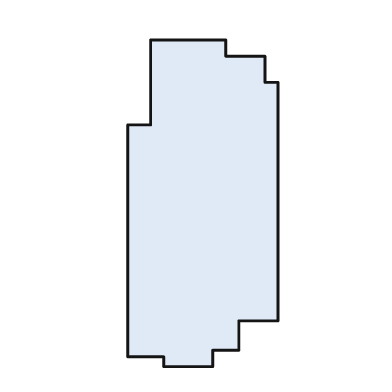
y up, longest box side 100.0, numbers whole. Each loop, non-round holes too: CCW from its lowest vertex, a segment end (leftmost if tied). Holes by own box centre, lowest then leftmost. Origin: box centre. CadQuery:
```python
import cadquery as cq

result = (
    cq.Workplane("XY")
    .moveTo(-12.0, -50.0)
    .lineTo(3.0, -50.0)
    .lineTo(3.0, -45.0)
    .lineTo(11.0, -45.0)
    .lineTo(11.0, -36.0)
    .lineTo(23.0, -36.0)
    .lineTo(23.0, 37.0)
    .lineTo(19.0, 37.0)
    .lineTo(19.0, 45.0)
    .lineTo(7.0, 45.0)
    .lineTo(7.0, 50.0)
    .lineTo(-16.0, 50.0)
    .lineTo(-16.0, 24.0)
    .lineTo(-23.0, 24.0)
    .lineTo(-23.0, -47.0)
    .lineTo(-12.0, -47.0)
    .close()
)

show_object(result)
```